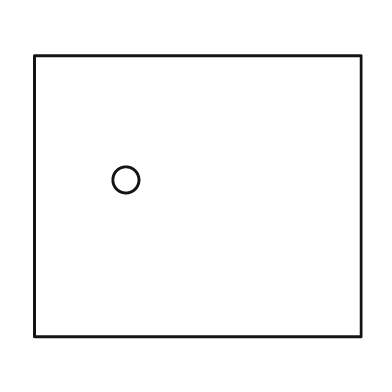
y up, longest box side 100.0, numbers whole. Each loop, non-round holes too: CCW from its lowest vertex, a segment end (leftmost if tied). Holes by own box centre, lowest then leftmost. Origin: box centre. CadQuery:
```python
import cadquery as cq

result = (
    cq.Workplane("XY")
    .moveTo(-50.0, -43.0)
    .lineTo(50.0, -43.0)
    .lineTo(50.0, 43.0)
    .lineTo(-50.0, 43.0)
    .close()
    .moveTo(-22.0, 5.0)
    .circle(4.0)
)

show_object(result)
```